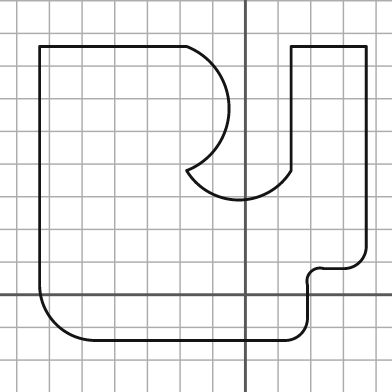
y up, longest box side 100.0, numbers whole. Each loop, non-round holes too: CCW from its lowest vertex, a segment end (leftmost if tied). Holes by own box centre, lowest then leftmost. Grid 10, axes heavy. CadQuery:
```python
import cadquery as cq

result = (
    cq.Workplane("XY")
    .moveTo(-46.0, -14.0)
    .lineTo(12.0, -14.0)
    .threePointArc((17.0, -12.0), (19.0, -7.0))
    .lineTo(19.0, 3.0)
    .threePointArc((20.0, 7.0), (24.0, 8.0))
    .lineTo(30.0, 8.0)
    .threePointArc((35.0, 10.0), (37.0, 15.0))
    .lineTo(37.0, 76.0)
    .lineTo(14.0, 76.0)
    .lineTo(14.0, 38.0)
    .threePointArc((-2.0, 29.0), (-18.0, 38.0))
    .threePointArc((-5.0, 57.0), (-18.0, 76.0))
    .lineTo(-63.0, 76.0)
    .lineTo(-63.0, 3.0)
    .threePointArc((-58.0, -9.0), (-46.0, -14.0))
    .close()
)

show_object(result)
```